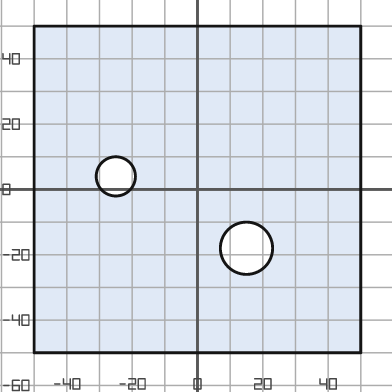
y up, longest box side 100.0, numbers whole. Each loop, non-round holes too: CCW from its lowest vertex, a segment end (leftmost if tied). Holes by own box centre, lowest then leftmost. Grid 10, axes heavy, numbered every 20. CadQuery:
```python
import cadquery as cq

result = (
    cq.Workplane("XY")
    .moveTo(-50.0, -50.0)
    .lineTo(50.0, -50.0)
    .lineTo(50.0, 50.0)
    .lineTo(-50.0, 50.0)
    .close()
    .moveTo(15.0, -18.0)
    .circle(8.0)
    .moveTo(-25.0, 4.0)
    .circle(6.0)
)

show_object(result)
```